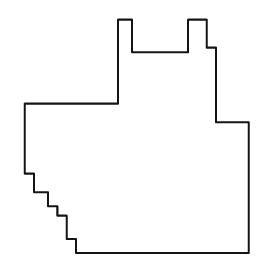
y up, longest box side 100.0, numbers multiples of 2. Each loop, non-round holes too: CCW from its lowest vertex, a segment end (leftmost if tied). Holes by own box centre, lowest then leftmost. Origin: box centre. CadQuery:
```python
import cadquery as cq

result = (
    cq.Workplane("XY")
    .moveTo(-26.0, -50.0)
    .lineTo(48.0, -50.0)
    .lineTo(48.0, 6.0)
    .lineTo(34.0, 6.0)
    .lineTo(34.0, 38.0)
    .lineTo(30.0, 38.0)
    .lineTo(30.0, 50.0)
    .lineTo(22.0, 50.0)
    .lineTo(22.0, 36.0)
    .lineTo(-2.0, 36.0)
    .lineTo(-2.0, 50.0)
    .lineTo(-8.0, 50.0)
    .lineTo(-8.0, 14.0)
    .lineTo(-48.0, 14.0)
    .lineTo(-48.0, -16.0)
    .lineTo(-44.0, -16.0)
    .lineTo(-44.0, -24.0)
    .lineTo(-38.0, -24.0)
    .lineTo(-38.0, -30.0)
    .lineTo(-34.0, -30.0)
    .lineTo(-34.0, -34.0)
    .lineTo(-30.0, -34.0)
    .lineTo(-30.0, -44.0)
    .lineTo(-26.0, -44.0)
    .close()
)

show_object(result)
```